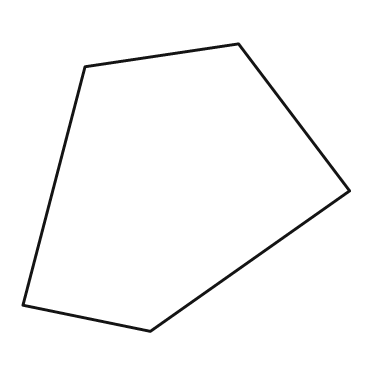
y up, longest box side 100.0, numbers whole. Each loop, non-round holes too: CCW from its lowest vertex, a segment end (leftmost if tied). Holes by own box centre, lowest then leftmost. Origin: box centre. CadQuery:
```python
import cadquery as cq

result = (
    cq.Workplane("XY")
    .moveTo(-11.0, -44.0)
    .lineTo(50.0, -1.0)
    .lineTo(16.0, 44.0)
    .lineTo(-31.0, 37.0)
    .lineTo(-50.0, -36.0)
    .close()
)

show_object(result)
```